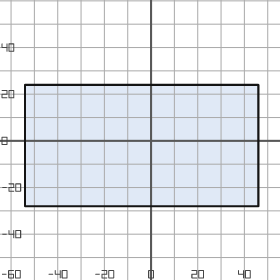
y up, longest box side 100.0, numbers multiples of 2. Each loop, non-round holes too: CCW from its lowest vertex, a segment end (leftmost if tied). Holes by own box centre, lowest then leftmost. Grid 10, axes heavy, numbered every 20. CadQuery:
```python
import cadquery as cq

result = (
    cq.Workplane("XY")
    .moveTo(-54.0, -28.0)
    .lineTo(46.0, -28.0)
    .lineTo(46.0, 24.0)
    .lineTo(-54.0, 24.0)
    .close()
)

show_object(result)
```